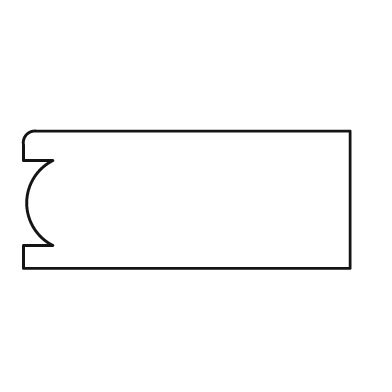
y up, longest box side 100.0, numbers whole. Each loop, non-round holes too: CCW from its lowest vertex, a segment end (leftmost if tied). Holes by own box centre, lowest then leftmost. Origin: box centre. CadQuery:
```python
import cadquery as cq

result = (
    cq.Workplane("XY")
    .moveTo(-50.0, -21.0)
    .lineTo(50.0, -21.0)
    .lineTo(50.0, 21.0)
    .lineTo(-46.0, 21.0)
    .threePointArc((-49.0, 20.0), (-50.0, 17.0))
    .lineTo(-50.0, 12.0)
    .lineTo(-41.0, 12.0)
    .threePointArc((-49.0, -1.0), (-41.0, -14.0))
    .lineTo(-50.0, -14.0)
    .close()
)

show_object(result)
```